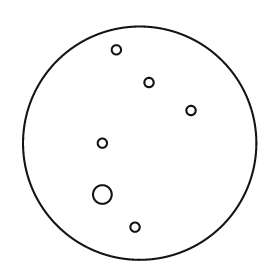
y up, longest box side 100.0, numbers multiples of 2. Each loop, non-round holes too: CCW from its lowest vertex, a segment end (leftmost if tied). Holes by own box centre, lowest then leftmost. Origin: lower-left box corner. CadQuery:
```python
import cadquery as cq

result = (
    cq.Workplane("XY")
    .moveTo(50.0, 50.0)
    .circle(50.0)
    .moveTo(48.0, 14.0)
    .circle(2.0)
    .moveTo(34.0, 28.0)
    .circle(4.0)
    .moveTo(34.0, 50.0)
    .circle(2.0)
    .moveTo(72.0, 64.0)
    .circle(2.0)
    .moveTo(54.0, 76.0)
    .circle(2.0)
    .moveTo(40.0, 90.0)
    .circle(2.0)
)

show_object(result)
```